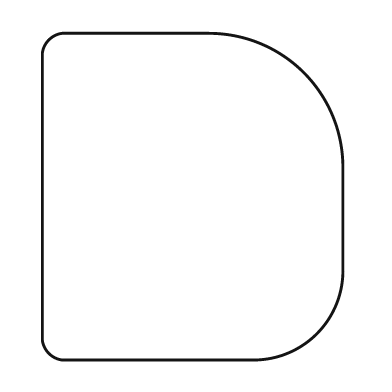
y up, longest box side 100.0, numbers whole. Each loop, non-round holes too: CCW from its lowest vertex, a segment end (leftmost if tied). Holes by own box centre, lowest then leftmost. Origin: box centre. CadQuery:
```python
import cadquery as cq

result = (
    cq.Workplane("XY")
    .moveTo(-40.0, -50.0)
    .lineTo(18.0, -50.0)
    .threePointArc((38.0, -42.0), (46.0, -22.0))
    .lineTo(46.0, 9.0)
    .threePointArc((34.0, 38.0), (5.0, 50.0))
    .lineTo(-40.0, 50.0)
    .threePointArc((-44.0, 48.0), (-46.0, 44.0))
    .lineTo(-46.0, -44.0)
    .threePointArc((-44.0, -48.0), (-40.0, -50.0))
    .close()
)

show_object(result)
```